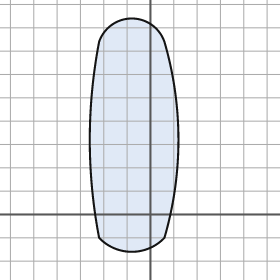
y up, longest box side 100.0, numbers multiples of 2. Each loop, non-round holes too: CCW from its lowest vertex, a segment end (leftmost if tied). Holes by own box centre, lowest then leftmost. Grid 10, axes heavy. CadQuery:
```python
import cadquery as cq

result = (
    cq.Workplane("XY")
    .moveTo(-22.0, -10.0)
    .threePointArc((-8.0, -16.0), (6.0, -10.0))
    .threePointArc((12.0, 32.0), (6.0, 74.0))
    .threePointArc((-8.0, 84.0), (-22.0, 74.0))
    .threePointArc((-26.0, 32.0), (-22.0, -10.0))
    .close()
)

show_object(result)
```